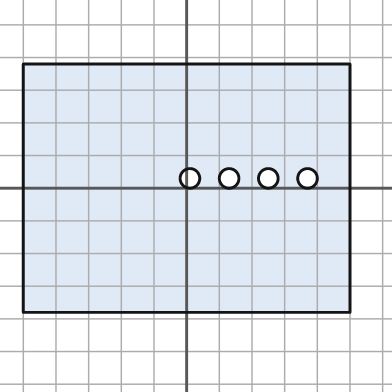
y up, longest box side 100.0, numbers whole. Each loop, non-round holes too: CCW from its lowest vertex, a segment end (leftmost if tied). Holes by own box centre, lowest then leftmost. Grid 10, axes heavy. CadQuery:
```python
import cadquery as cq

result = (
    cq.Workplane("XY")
    .moveTo(-50.0, -38.0)
    .lineTo(50.0, -38.0)
    .lineTo(50.0, 38.0)
    .lineTo(-50.0, 38.0)
    .close()
    .moveTo(1.0, 3.0)
    .circle(3.0)
    .moveTo(13.0, 3.0)
    .circle(3.0)
    .moveTo(25.0, 3.0)
    .circle(3.0)
    .moveTo(37.0, 3.0)
    .circle(3.0)
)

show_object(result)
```